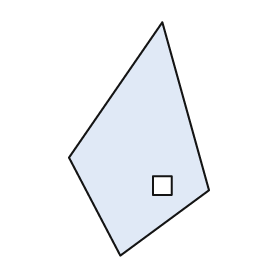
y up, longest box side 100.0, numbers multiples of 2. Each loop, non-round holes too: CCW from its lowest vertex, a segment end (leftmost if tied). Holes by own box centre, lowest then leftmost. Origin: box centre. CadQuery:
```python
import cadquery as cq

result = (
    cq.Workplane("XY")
    .moveTo(-8.0, -50.0)
    .lineTo(30.0, -22.0)
    .lineTo(10.0, 50.0)
    .lineTo(-30.0, -8.0)
    .close()
    .moveTo(6.0, -24.0)
    .lineTo(14.0, -24.0)
    .lineTo(14.0, -16.0)
    .lineTo(6.0, -16.0)
    .close()
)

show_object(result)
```